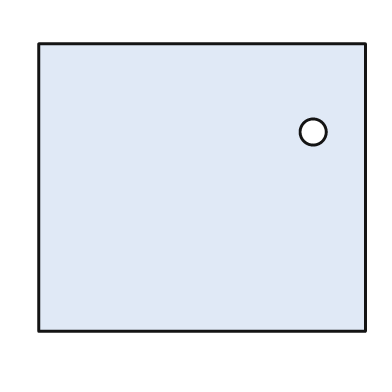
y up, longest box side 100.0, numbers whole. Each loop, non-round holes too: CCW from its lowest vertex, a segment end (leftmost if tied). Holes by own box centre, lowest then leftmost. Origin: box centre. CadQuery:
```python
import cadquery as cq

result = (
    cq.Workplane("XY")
    .moveTo(-50.0, -44.0)
    .lineTo(50.0, -44.0)
    .lineTo(50.0, 44.0)
    .lineTo(-50.0, 44.0)
    .close()
    .moveTo(34.0, 17.0)
    .circle(4.0)
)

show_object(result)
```